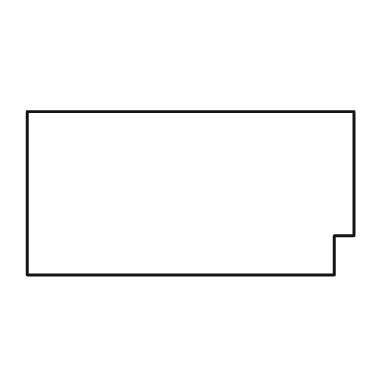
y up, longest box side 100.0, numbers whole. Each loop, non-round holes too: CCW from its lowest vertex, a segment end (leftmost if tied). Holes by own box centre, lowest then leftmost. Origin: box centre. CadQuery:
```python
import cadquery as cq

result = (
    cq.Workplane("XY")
    .moveTo(-50.0, -25.0)
    .lineTo(44.0, -25.0)
    .lineTo(44.0, -13.0)
    .lineTo(50.0, -13.0)
    .lineTo(50.0, 25.0)
    .lineTo(-50.0, 25.0)
    .close()
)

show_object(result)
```